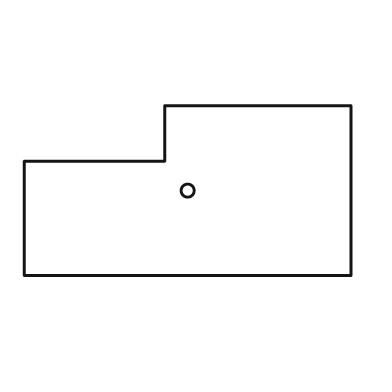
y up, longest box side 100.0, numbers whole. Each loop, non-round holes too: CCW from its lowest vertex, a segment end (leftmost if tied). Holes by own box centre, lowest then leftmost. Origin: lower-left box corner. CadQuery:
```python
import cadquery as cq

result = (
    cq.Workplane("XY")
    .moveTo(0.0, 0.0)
    .lineTo(100.0, 0.0)
    .lineTo(100.0, 52.0)
    .lineTo(43.0, 52.0)
    .lineTo(43.0, 35.0)
    .lineTo(0.0, 35.0)
    .close()
    .moveTo(50.0, 26.0)
    .circle(2.0)
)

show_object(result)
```